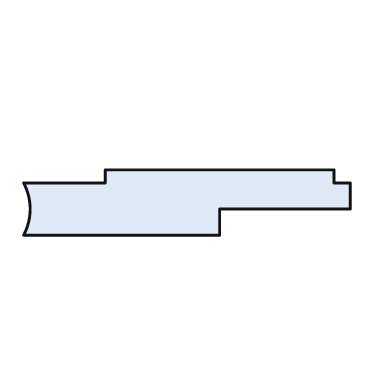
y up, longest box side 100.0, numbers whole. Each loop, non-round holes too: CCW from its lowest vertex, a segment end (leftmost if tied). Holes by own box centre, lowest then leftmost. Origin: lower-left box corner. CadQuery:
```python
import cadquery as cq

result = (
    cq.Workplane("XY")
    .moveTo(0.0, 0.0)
    .lineTo(60.0, 0.0)
    .lineTo(60.0, 8.0)
    .lineTo(100.0, 8.0)
    .lineTo(100.0, 16.0)
    .lineTo(95.0, 16.0)
    .lineTo(95.0, 20.0)
    .lineTo(25.0, 20.0)
    .lineTo(25.0, 16.0)
    .lineTo(0.0, 16.0)
    .threePointArc((2.0, 8.0), (0.0, 0.0))
    .close()
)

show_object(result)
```